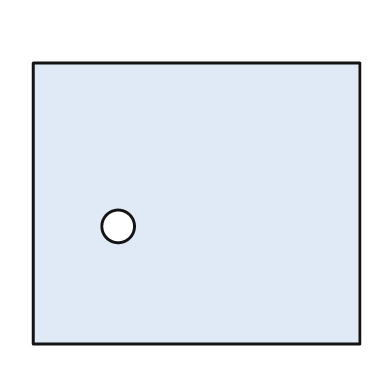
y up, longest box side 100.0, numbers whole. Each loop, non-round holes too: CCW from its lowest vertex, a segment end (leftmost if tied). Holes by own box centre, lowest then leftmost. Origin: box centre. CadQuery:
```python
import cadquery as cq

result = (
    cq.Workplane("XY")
    .moveTo(-50.0, -43.0)
    .lineTo(50.0, -43.0)
    .lineTo(50.0, 43.0)
    .lineTo(-50.0, 43.0)
    .close()
    .moveTo(-24.0, -7.0)
    .circle(5.0)
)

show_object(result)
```